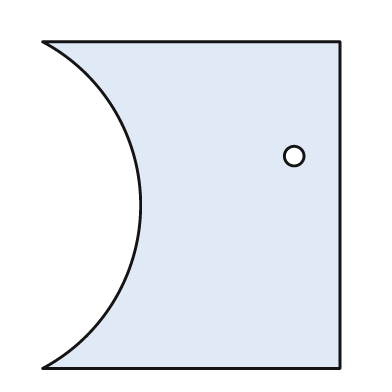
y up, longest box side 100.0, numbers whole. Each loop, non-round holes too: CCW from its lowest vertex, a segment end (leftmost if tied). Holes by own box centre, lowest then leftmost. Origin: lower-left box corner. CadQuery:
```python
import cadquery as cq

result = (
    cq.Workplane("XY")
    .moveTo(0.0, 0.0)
    .lineTo(91.0, 0.0)
    .lineTo(91.0, 100.0)
    .lineTo(0.0, 100.0)
    .threePointArc((30.0, 50.0), (0.0, 0.0))
    .close()
    .moveTo(77.0, 65.0)
    .circle(3.0)
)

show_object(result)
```